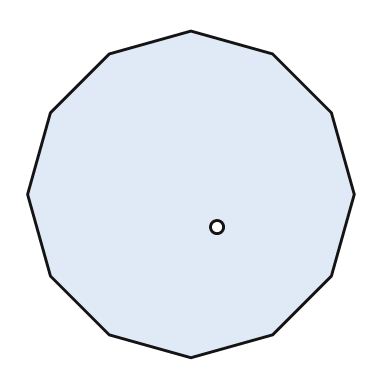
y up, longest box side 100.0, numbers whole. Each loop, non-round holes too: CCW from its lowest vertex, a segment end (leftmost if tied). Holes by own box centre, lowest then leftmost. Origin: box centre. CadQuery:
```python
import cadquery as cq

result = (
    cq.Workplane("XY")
    .moveTo(0.0, -50.0)
    .lineTo(25.0, -43.0)
    .lineTo(43.0, -25.0)
    .lineTo(50.0, 0.0)
    .lineTo(43.0, 25.0)
    .lineTo(25.0, 43.0)
    .lineTo(0.0, 50.0)
    .lineTo(-25.0, 43.0)
    .lineTo(-43.0, 25.0)
    .lineTo(-50.0, 0.0)
    .lineTo(-43.0, -25.0)
    .lineTo(-25.0, -43.0)
    .close()
    .moveTo(8.0, -10.0)
    .circle(2.0)
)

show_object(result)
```